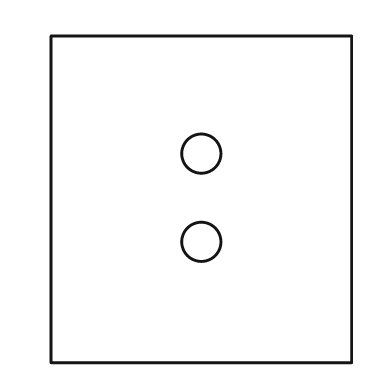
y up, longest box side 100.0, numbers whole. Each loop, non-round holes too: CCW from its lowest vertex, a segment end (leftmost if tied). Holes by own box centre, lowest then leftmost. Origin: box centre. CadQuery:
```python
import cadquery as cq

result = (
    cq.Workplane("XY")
    .moveTo(-46.0, -50.0)
    .lineTo(46.0, -50.0)
    .lineTo(46.0, 50.0)
    .lineTo(-46.0, 50.0)
    .close()
    .moveTo(0.0, -13.0)
    .circle(6.0)
    .moveTo(0.0, 14.0)
    .circle(6.0)
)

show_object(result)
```